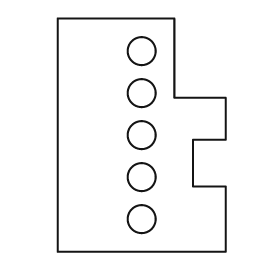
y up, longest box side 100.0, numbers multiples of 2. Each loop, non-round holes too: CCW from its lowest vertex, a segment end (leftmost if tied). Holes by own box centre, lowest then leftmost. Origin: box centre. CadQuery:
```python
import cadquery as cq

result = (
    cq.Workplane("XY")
    .moveTo(-36.0, -50.0)
    .lineTo(36.0, -50.0)
    .lineTo(36.0, -22.0)
    .lineTo(22.0, -22.0)
    .lineTo(22.0, -2.0)
    .lineTo(36.0, -2.0)
    .lineTo(36.0, 16.0)
    .lineTo(14.0, 16.0)
    .lineTo(14.0, 50.0)
    .lineTo(-36.0, 50.0)
    .close()
    .moveTo(0.0, -36.0)
    .circle(6.0)
    .moveTo(0.0, -18.0)
    .circle(6.0)
    .moveTo(0.0, 0.0)
    .circle(6.0)
    .moveTo(0.0, 18.0)
    .circle(6.0)
    .moveTo(0.0, 36.0)
    .circle(6.0)
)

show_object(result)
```